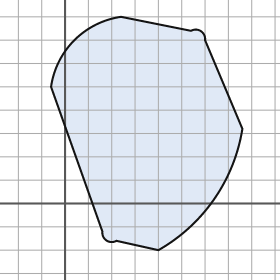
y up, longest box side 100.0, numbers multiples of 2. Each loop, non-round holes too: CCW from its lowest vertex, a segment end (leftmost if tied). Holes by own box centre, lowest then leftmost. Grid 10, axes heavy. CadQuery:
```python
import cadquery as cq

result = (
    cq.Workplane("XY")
    .moveTo(40.0, -20.0)
    .threePointArc((64.0, 2.0), (76.0, 32.0))
    .lineTo(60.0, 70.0)
    .threePointArc((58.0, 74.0), (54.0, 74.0))
    .lineTo(24.0, 80.0)
    .threePointArc((4.0, 70.0), (-6.0, 50.0))
    .lineTo(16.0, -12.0)
    .threePointArc((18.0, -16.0), (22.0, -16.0))
    .close()
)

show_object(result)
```